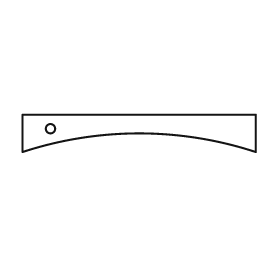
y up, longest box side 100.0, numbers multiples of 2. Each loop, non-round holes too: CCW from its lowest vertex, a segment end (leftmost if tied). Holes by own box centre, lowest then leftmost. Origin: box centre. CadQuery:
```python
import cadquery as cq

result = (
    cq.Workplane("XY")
    .moveTo(-50.0, -8.0)
    .threePointArc((0.0, 0.0), (50.0, -8.0))
    .lineTo(50.0, 8.0)
    .lineTo(-50.0, 8.0)
    .close()
    .moveTo(-38.0, 2.0)
    .circle(2.0)
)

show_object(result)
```